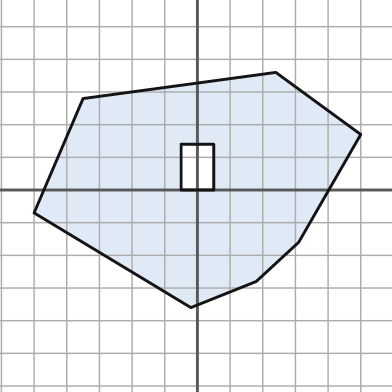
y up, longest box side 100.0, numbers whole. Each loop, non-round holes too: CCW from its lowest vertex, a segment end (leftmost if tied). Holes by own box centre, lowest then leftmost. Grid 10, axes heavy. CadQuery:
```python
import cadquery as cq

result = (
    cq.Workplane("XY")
    .moveTo(-2.0, -36.0)
    .lineTo(18.0, -28.0)
    .lineTo(31.0, -16.0)
    .lineTo(50.0, 17.0)
    .lineTo(24.0, 36.0)
    .lineTo(-35.0, 28.0)
    .lineTo(-50.0, -7.0)
    .close()
    .moveTo(-5.0, 0.0)
    .lineTo(5.0, 0.0)
    .lineTo(5.0, 14.0)
    .lineTo(-5.0, 14.0)
    .close()
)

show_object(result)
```